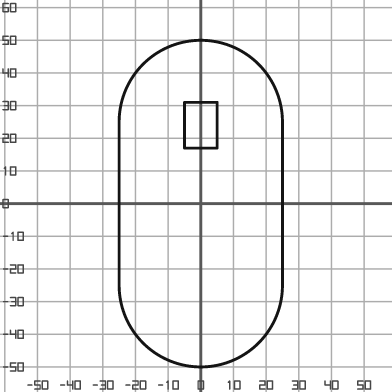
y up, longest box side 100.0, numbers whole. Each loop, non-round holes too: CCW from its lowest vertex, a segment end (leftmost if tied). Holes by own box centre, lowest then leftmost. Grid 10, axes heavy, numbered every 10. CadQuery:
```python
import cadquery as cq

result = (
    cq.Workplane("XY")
    .moveTo(-25.0, -25.0)
    .threePointArc((0.0, -50.0), (25.0, -25.0))
    .lineTo(25.0, 25.0)
    .threePointArc((0.0, 50.0), (-25.0, 25.0))
    .close()
    .moveTo(-5.0, 17.0)
    .lineTo(5.0, 17.0)
    .lineTo(5.0, 31.0)
    .lineTo(-5.0, 31.0)
    .close()
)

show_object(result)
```